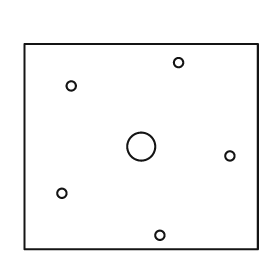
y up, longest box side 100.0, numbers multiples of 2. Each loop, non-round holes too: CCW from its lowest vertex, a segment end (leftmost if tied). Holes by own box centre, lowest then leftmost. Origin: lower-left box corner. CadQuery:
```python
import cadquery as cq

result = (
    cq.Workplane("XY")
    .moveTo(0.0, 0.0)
    .lineTo(100.0, 0.0)
    .lineTo(100.0, 88.0)
    .lineTo(0.0, 88.0)
    .close()
    .moveTo(58.0, 6.0)
    .circle(2.0)
    .moveTo(16.0, 24.0)
    .circle(2.0)
    .moveTo(88.0, 40.0)
    .circle(2.0)
    .moveTo(50.0, 44.0)
    .circle(6.0)
    .moveTo(20.0, 70.0)
    .circle(2.0)
    .moveTo(66.0, 80.0)
    .circle(2.0)
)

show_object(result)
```